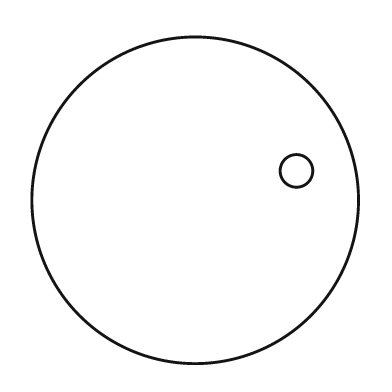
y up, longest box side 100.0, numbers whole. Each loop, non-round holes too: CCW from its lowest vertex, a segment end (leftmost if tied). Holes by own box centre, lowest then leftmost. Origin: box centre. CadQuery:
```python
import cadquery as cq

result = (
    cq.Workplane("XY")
    .moveTo(0.0, 0.0)
    .circle(50.0)
    .moveTo(31.0, 9.0)
    .circle(5.0)
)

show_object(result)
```